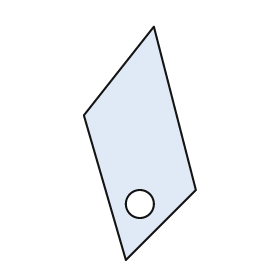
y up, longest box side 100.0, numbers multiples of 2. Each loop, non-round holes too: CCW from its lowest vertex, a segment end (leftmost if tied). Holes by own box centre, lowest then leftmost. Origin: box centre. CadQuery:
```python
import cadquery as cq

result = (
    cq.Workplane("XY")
    .moveTo(-6.0, -50.0)
    .lineTo(24.0, -20.0)
    .lineTo(6.0, 50.0)
    .lineTo(-24.0, 12.0)
    .close()
    .moveTo(0.0, -26.0)
    .circle(6.0)
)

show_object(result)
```